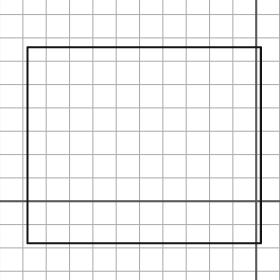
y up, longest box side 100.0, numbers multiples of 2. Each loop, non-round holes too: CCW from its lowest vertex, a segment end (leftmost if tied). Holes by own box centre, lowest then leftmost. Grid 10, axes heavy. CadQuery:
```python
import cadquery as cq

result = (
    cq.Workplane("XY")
    .moveTo(-98.0, -18.0)
    .lineTo(2.0, -18.0)
    .lineTo(2.0, 66.0)
    .lineTo(-98.0, 66.0)
    .close()
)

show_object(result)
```